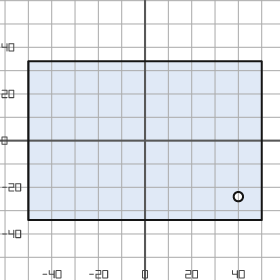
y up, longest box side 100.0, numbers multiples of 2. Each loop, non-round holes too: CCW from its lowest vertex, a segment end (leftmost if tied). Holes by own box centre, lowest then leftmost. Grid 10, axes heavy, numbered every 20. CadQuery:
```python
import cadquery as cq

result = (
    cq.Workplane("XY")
    .moveTo(-50.0, -34.0)
    .lineTo(50.0, -34.0)
    .lineTo(50.0, 34.0)
    .lineTo(-50.0, 34.0)
    .close()
    .moveTo(40.0, -24.0)
    .circle(2.0)
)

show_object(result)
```